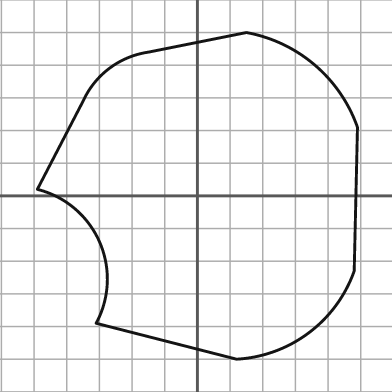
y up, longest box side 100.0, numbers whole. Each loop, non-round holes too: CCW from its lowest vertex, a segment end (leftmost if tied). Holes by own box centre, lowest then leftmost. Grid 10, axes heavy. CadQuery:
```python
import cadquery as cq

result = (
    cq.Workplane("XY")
    .moveTo(12.0, -50.0)
    .threePointArc((34.0, -42.0), (48.0, -23.0))
    .lineTo(49.0, 21.0)
    .threePointArc((36.0, 40.0), (15.0, 50.0))
    .lineTo(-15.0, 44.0)
    .threePointArc((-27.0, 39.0), (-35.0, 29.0))
    .lineTo(-49.0, 2.0)
    .threePointArc((-30.0, -14.0), (-31.0, -39.0))
    .close()
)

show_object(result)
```